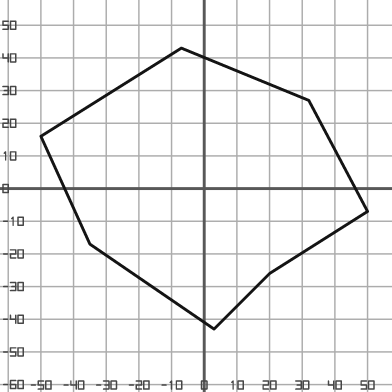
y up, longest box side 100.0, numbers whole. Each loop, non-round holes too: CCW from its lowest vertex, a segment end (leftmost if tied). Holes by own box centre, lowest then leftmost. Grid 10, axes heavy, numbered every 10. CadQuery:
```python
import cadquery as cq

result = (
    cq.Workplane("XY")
    .moveTo(3.0, -43.0)
    .lineTo(20.0, -26.0)
    .lineTo(50.0, -7.0)
    .lineTo(32.0, 27.0)
    .lineTo(-7.0, 43.0)
    .lineTo(-50.0, 16.0)
    .lineTo(-35.0, -17.0)
    .close()
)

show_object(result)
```